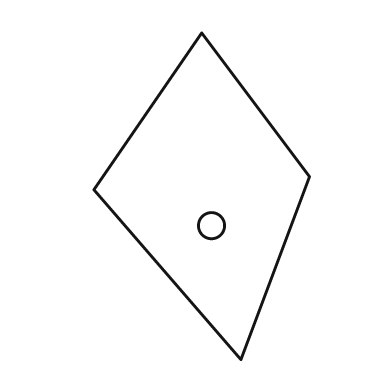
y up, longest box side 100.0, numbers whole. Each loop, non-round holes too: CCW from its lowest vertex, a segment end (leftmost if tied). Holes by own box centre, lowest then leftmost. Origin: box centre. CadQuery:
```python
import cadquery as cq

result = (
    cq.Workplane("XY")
    .moveTo(12.0, -50.0)
    .lineTo(33.0, 6.0)
    .lineTo(0.0, 50.0)
    .lineTo(-33.0, 2.0)
    .close()
    .moveTo(3.0, -9.0)
    .circle(4.0)
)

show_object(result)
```